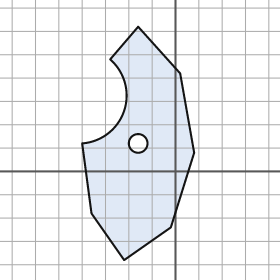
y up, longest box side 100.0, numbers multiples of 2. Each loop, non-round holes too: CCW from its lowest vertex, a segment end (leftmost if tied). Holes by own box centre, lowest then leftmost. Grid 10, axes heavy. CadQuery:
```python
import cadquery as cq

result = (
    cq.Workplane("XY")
    .moveTo(-22.0, -38.0)
    .lineTo(-2.0, -24.0)
    .lineTo(8.0, 8.0)
    .lineTo(2.0, 42.0)
    .lineTo(-16.0, 62.0)
    .lineTo(-28.0, 48.0)
    .threePointArc((-22.0, 26.0), (-40.0, 12.0))
    .lineTo(-36.0, -18.0)
    .close()
    .moveTo(-16.0, 12.0)
    .circle(4.0)
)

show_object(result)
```